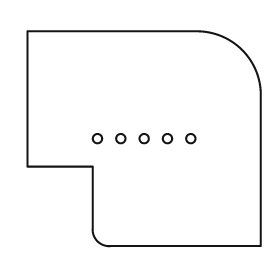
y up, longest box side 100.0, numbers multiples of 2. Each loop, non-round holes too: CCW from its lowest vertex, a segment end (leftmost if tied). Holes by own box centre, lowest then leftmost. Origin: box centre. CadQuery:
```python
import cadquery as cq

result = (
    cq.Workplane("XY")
    .moveTo(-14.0, -46.0)
    .lineTo(50.0, -46.0)
    .lineTo(50.0, 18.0)
    .threePointArc((42.0, 38.0), (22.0, 46.0))
    .lineTo(-50.0, 46.0)
    .lineTo(-50.0, -12.0)
    .lineTo(-22.0, -12.0)
    .lineTo(-22.0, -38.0)
    .threePointArc((-20.0, -44.0), (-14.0, -46.0))
    .close()
    .moveTo(-20.0, 0.0)
    .circle(2.0)
    .moveTo(-10.0, 0.0)
    .circle(2.0)
    .moveTo(0.0, 0.0)
    .circle(2.0)
    .moveTo(10.0, 0.0)
    .circle(2.0)
    .moveTo(20.0, 0.0)
    .circle(2.0)
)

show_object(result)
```